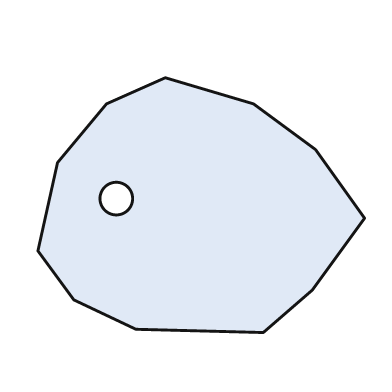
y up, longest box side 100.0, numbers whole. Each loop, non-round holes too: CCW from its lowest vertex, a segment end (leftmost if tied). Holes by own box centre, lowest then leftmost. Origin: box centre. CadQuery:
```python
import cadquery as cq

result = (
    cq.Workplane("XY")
    .moveTo(19.0, -39.0)
    .lineTo(34.0, -26.0)
    .lineTo(50.0, -4.0)
    .lineTo(35.0, 17.0)
    .lineTo(16.0, 31.0)
    .lineTo(-11.0, 39.0)
    .lineTo(-29.0, 31.0)
    .lineTo(-44.0, 13.0)
    .lineTo(-50.0, -14.0)
    .lineTo(-39.0, -29.0)
    .lineTo(-20.0, -38.0)
    .close()
    .moveTo(-26.0, 2.0)
    .circle(5.0)
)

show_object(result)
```